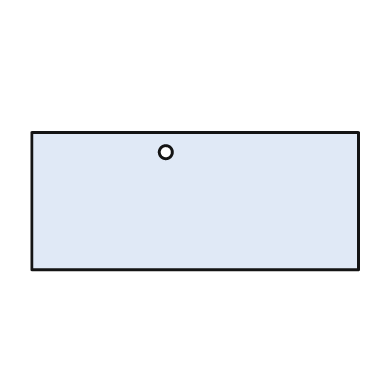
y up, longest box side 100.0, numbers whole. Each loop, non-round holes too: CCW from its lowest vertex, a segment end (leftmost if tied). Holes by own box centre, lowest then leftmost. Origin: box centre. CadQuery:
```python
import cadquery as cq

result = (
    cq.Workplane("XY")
    .moveTo(-50.0, -21.0)
    .lineTo(50.0, -21.0)
    .lineTo(50.0, 21.0)
    .lineTo(-50.0, 21.0)
    .close()
    .moveTo(-9.0, 15.0)
    .circle(2.0)
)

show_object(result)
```